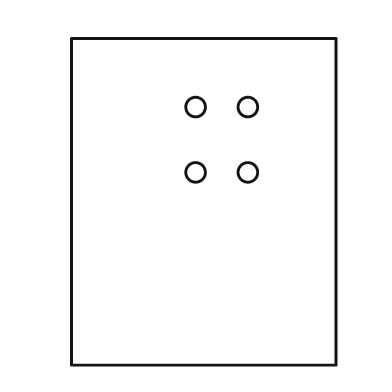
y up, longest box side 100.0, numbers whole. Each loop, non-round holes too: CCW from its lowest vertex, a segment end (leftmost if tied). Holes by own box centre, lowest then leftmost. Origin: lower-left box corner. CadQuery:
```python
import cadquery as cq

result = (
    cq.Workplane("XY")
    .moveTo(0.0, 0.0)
    .lineTo(81.0, 0.0)
    .lineTo(81.0, 100.0)
    .lineTo(0.0, 100.0)
    .close()
    .moveTo(38.0, 59.0)
    .circle(3.0)
    .moveTo(54.0, 59.0)
    .circle(3.0)
    .moveTo(38.0, 79.0)
    .circle(3.0)
    .moveTo(54.0, 79.0)
    .circle(3.0)
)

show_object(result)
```